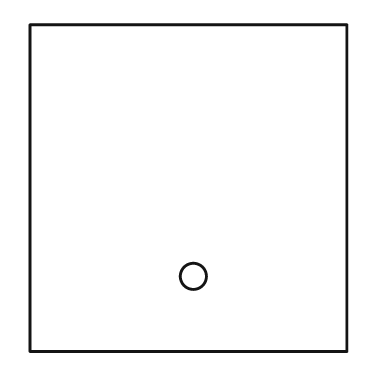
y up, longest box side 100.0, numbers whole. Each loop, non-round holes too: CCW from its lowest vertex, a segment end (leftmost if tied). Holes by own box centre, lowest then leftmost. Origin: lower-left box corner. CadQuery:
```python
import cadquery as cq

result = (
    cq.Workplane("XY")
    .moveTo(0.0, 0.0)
    .lineTo(97.0, 0.0)
    .lineTo(97.0, 100.0)
    .lineTo(0.0, 100.0)
    .close()
    .moveTo(50.0, 23.0)
    .circle(4.0)
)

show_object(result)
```